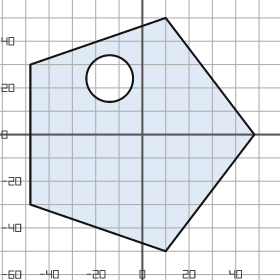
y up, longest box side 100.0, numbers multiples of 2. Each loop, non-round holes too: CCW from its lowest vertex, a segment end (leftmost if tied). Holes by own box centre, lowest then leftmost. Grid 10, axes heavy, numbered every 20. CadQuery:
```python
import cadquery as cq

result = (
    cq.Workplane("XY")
    .moveTo(10.0, -50.0)
    .lineTo(48.0, 0.0)
    .lineTo(10.0, 50.0)
    .lineTo(-48.0, 30.0)
    .lineTo(-48.0, -30.0)
    .close()
    .moveTo(-14.0, 24.0)
    .circle(10.0)
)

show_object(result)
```